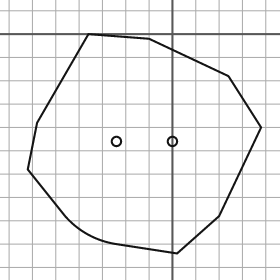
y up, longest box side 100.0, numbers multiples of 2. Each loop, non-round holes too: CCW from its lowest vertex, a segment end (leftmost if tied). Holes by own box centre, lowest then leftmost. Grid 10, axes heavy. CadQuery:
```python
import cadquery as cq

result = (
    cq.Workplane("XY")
    .moveTo(2.0, -94.0)
    .lineTo(20.0, -78.0)
    .lineTo(38.0, -40.0)
    .lineTo(24.0, -18.0)
    .lineTo(-10.0, -2.0)
    .lineTo(-36.0, 0.0)
    .lineTo(-58.0, -38.0)
    .lineTo(-62.0, -58.0)
    .lineTo(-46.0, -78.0)
    .threePointArc((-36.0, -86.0), (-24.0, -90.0))
    .close()
    .moveTo(-24.0, -46.0)
    .circle(2.0)
    .moveTo(0.0, -46.0)
    .circle(2.0)
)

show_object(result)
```